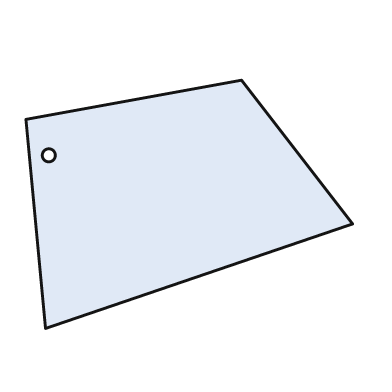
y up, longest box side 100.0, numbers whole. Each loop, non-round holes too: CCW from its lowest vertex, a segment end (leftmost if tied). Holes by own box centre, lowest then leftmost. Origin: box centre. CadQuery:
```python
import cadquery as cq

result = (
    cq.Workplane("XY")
    .moveTo(-44.0, -38.0)
    .lineTo(50.0, -6.0)
    .lineTo(16.0, 38.0)
    .lineTo(-50.0, 26.0)
    .close()
    .moveTo(-43.0, 15.0)
    .circle(2.0)
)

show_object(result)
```